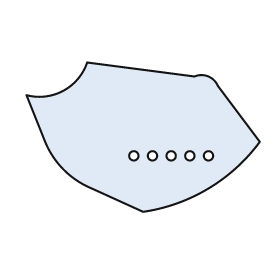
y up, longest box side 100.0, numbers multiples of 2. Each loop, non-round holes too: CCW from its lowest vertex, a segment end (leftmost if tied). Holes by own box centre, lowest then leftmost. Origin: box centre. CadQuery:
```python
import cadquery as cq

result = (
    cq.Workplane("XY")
    .moveTo(0.0, -32.0)
    .threePointArc((28.0, -22.0), (50.0, -2.0))
    .lineTo(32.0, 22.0)
    .threePointArc((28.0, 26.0), (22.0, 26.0))
    .lineTo(-24.0, 32.0)
    .threePointArc((-34.0, 20.0), (-50.0, 18.0))
    .lineTo(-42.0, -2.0)
    .threePointArc((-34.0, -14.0), (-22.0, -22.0))
    .close()
    .moveTo(-4.0, -8.0)
    .circle(2.0)
    .moveTo(4.0, -8.0)
    .circle(2.0)
    .moveTo(12.0, -8.0)
    .circle(2.0)
    .moveTo(20.0, -8.0)
    .circle(2.0)
    .moveTo(28.0, -8.0)
    .circle(2.0)
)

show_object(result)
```